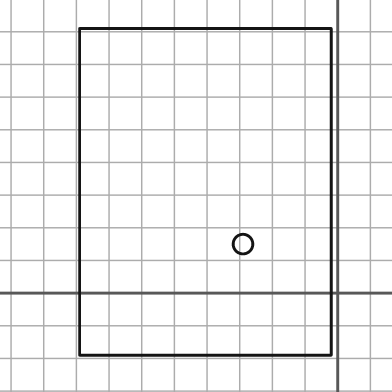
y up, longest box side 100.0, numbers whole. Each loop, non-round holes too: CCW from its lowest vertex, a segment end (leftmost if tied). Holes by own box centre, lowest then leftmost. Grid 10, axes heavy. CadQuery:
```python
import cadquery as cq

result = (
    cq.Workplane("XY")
    .moveTo(-79.0, -19.0)
    .lineTo(-2.0, -19.0)
    .lineTo(-2.0, 81.0)
    .lineTo(-79.0, 81.0)
    .close()
    .moveTo(-29.0, 15.0)
    .circle(3.0)
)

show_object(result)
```